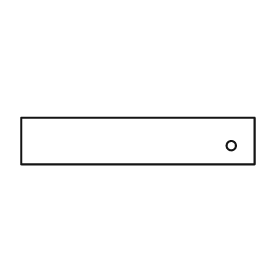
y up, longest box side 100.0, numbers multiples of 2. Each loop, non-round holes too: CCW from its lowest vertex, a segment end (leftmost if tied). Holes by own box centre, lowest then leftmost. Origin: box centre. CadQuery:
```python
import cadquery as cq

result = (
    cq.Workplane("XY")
    .moveTo(-50.0, -10.0)
    .lineTo(50.0, -10.0)
    .lineTo(50.0, 10.0)
    .lineTo(-50.0, 10.0)
    .close()
    .moveTo(40.0, -2.0)
    .circle(2.0)
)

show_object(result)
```